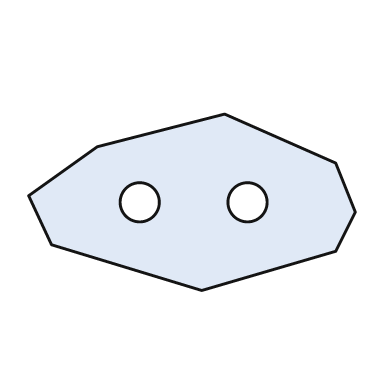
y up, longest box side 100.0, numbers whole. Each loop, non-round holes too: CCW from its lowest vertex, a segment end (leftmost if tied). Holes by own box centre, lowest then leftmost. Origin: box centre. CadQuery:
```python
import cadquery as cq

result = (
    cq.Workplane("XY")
    .moveTo(3.0, -27.0)
    .lineTo(44.0, -15.0)
    .lineTo(50.0, -3.0)
    .lineTo(44.0, 12.0)
    .lineTo(10.0, 27.0)
    .lineTo(-29.0, 17.0)
    .lineTo(-50.0, 2.0)
    .lineTo(-43.0, -13.0)
    .close()
    .moveTo(-16.0, 0.0)
    .circle(6.0)
    .moveTo(17.0, 0.0)
    .circle(6.0)
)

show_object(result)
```